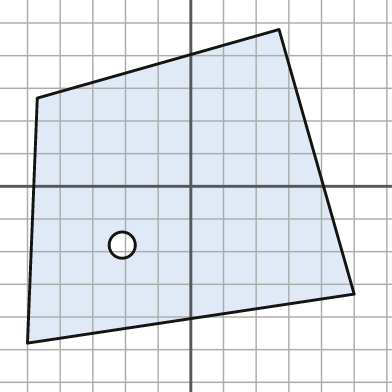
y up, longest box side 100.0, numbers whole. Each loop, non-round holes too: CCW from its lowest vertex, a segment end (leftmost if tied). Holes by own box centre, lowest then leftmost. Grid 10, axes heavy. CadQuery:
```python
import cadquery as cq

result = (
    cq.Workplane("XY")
    .moveTo(-50.0, -48.0)
    .lineTo(50.0, -33.0)
    .lineTo(27.0, 48.0)
    .lineTo(-47.0, 27.0)
    .close()
    .moveTo(-21.0, -18.0)
    .circle(4.0)
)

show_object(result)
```